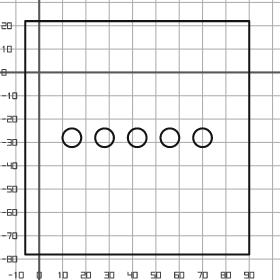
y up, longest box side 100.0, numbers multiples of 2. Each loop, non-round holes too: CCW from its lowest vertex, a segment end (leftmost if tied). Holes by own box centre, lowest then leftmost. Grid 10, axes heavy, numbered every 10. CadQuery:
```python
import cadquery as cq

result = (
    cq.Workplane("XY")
    .moveTo(-6.0, -78.0)
    .lineTo(90.0, -78.0)
    .lineTo(90.0, 22.0)
    .lineTo(-6.0, 22.0)
    .close()
    .moveTo(14.0, -28.0)
    .circle(4.0)
    .moveTo(28.0, -28.0)
    .circle(4.0)
    .moveTo(42.0, -28.0)
    .circle(4.0)
    .moveTo(56.0, -28.0)
    .circle(4.0)
    .moveTo(70.0, -28.0)
    .circle(4.0)
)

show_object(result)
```